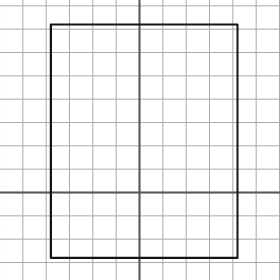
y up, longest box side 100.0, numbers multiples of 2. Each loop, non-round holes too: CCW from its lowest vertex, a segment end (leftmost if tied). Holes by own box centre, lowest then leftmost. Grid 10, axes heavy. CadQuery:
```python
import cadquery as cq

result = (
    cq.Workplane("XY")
    .moveTo(-38.0, -28.0)
    .lineTo(42.0, -28.0)
    .lineTo(42.0, 72.0)
    .lineTo(-38.0, 72.0)
    .close()
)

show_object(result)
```